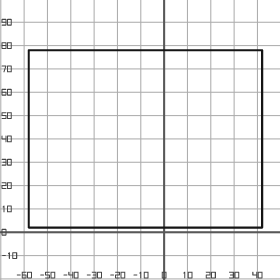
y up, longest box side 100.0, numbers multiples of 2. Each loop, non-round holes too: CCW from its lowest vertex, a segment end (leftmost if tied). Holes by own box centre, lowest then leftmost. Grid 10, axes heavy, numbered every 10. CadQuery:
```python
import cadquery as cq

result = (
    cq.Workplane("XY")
    .moveTo(-58.0, 2.0)
    .lineTo(42.0, 2.0)
    .lineTo(42.0, 78.0)
    .lineTo(-58.0, 78.0)
    .close()
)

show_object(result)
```